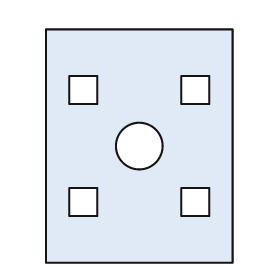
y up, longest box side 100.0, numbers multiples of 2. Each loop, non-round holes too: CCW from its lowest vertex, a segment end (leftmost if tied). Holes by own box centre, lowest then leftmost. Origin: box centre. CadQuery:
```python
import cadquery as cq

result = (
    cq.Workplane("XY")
    .moveTo(-40.0, -50.0)
    .lineTo(40.0, -50.0)
    .lineTo(40.0, 50.0)
    .lineTo(-40.0, 50.0)
    .close()
    .moveTo(-30.0, -30.0)
    .lineTo(-18.0, -30.0)
    .lineTo(-18.0, -18.0)
    .lineTo(-30.0, -18.0)
    .close()
    .moveTo(18.0, -30.0)
    .lineTo(30.0, -30.0)
    .lineTo(30.0, -18.0)
    .lineTo(18.0, -18.0)
    .close()
    .moveTo(0.0, 0.0)
    .circle(10.0)
    .moveTo(-30.0, 18.0)
    .lineTo(-18.0, 18.0)
    .lineTo(-18.0, 30.0)
    .lineTo(-30.0, 30.0)
    .close()
    .moveTo(18.0, 18.0)
    .lineTo(30.0, 18.0)
    .lineTo(30.0, 30.0)
    .lineTo(18.0, 30.0)
    .close()
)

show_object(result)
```